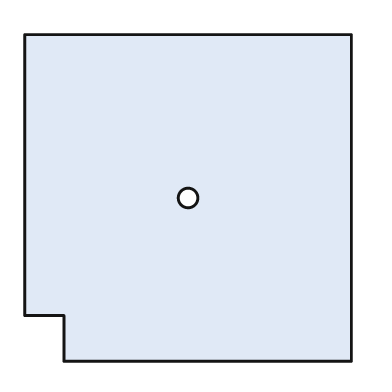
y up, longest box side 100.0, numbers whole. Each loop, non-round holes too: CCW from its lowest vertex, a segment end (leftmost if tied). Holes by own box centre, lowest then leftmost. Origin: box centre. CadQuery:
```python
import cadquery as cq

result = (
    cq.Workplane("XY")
    .moveTo(-38.0, -50.0)
    .lineTo(50.0, -50.0)
    .lineTo(50.0, 50.0)
    .lineTo(-50.0, 50.0)
    .lineTo(-50.0, -36.0)
    .lineTo(-38.0, -36.0)
    .close()
    .moveTo(0.0, 0.0)
    .circle(3.0)
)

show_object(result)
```